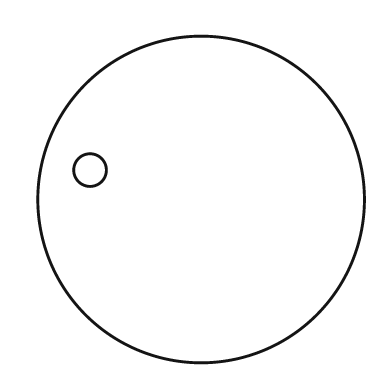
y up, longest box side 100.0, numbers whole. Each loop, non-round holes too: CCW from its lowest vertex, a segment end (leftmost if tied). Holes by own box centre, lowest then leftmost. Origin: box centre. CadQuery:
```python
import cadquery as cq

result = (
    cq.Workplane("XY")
    .moveTo(0.0, 0.0)
    .circle(50.0)
    .moveTo(-34.0, 9.0)
    .circle(5.0)
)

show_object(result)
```